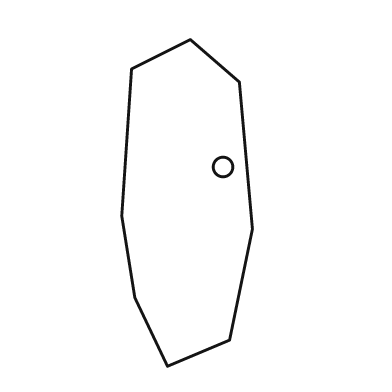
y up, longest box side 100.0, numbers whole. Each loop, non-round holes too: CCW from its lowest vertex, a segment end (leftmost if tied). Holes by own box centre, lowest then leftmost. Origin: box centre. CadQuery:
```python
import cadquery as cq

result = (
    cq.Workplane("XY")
    .moveTo(-6.0, -50.0)
    .lineTo(13.0, -42.0)
    .lineTo(20.0, -8.0)
    .lineTo(16.0, 37.0)
    .lineTo(1.0, 50.0)
    .lineTo(-17.0, 41.0)
    .lineTo(-20.0, -4.0)
    .lineTo(-16.0, -29.0)
    .close()
    .moveTo(11.0, 11.0)
    .circle(3.0)
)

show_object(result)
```